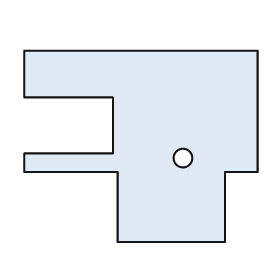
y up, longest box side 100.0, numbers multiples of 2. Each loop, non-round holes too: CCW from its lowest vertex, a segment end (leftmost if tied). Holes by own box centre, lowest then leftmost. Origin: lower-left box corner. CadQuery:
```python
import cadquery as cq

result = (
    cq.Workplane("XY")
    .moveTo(40.0, 0.0)
    .lineTo(86.0, 0.0)
    .lineTo(86.0, 30.0)
    .lineTo(100.0, 30.0)
    .lineTo(100.0, 82.0)
    .lineTo(0.0, 82.0)
    .lineTo(0.0, 62.0)
    .lineTo(38.0, 62.0)
    .lineTo(38.0, 38.0)
    .lineTo(0.0, 38.0)
    .lineTo(0.0, 30.0)
    .lineTo(40.0, 30.0)
    .close()
    .moveTo(68.0, 36.0)
    .circle(4.0)
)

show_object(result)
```